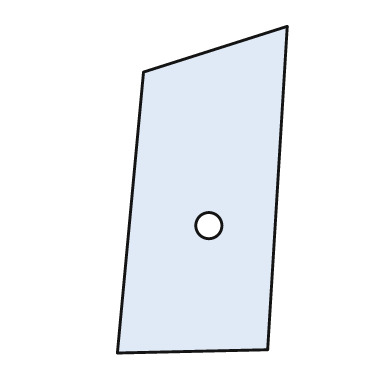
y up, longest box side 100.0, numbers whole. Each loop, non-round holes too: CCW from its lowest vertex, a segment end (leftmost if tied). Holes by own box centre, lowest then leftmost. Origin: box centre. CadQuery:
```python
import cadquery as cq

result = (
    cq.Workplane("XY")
    .moveTo(-26.0, -50.0)
    .lineTo(20.0, -49.0)
    .lineTo(26.0, 50.0)
    .lineTo(-18.0, 36.0)
    .close()
    .moveTo(2.0, -11.0)
    .circle(4.0)
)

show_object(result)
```